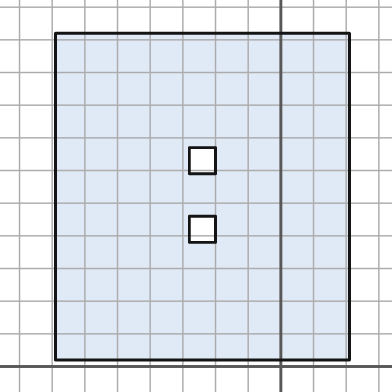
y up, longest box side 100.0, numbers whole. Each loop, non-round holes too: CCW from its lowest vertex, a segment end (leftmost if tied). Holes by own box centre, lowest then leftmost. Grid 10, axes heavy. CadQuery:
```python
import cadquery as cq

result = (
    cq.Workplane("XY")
    .moveTo(-69.0, 2.0)
    .lineTo(21.0, 2.0)
    .lineTo(21.0, 102.0)
    .lineTo(-69.0, 102.0)
    .close()
    .moveTo(-28.0, 38.0)
    .lineTo(-20.0, 38.0)
    .lineTo(-20.0, 46.0)
    .lineTo(-28.0, 46.0)
    .close()
    .moveTo(-28.0, 59.0)
    .lineTo(-20.0, 59.0)
    .lineTo(-20.0, 67.0)
    .lineTo(-28.0, 67.0)
    .close()
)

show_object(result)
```